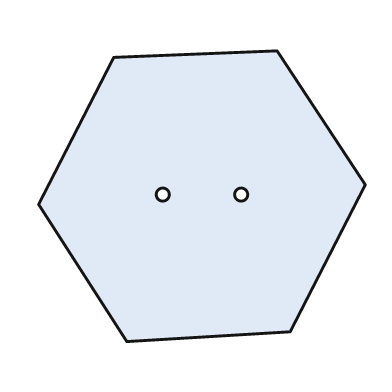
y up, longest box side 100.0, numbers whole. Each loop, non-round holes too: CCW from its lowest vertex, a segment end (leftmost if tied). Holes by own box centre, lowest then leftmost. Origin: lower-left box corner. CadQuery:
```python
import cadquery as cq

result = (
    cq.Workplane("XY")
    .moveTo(27.0, 0.0)
    .lineTo(77.0, 3.0)
    .lineTo(100.0, 48.0)
    .lineTo(73.0, 89.0)
    .lineTo(23.0, 87.0)
    .lineTo(0.0, 42.0)
    .close()
    .moveTo(38.0, 45.0)
    .circle(2.0)
    .moveTo(62.0, 45.0)
    .circle(2.0)
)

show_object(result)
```